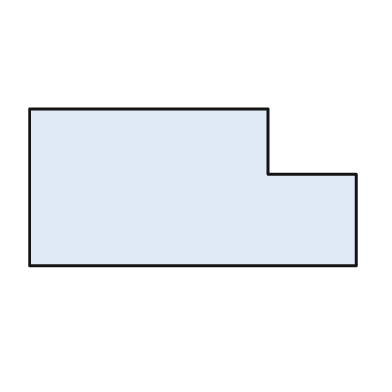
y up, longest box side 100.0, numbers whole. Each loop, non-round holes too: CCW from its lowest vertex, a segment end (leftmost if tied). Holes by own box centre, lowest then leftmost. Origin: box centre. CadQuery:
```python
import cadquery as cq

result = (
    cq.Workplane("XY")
    .moveTo(-50.0, -24.0)
    .lineTo(50.0, -24.0)
    .lineTo(50.0, 4.0)
    .lineTo(23.0, 4.0)
    .lineTo(23.0, 24.0)
    .lineTo(-50.0, 24.0)
    .close()
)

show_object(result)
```